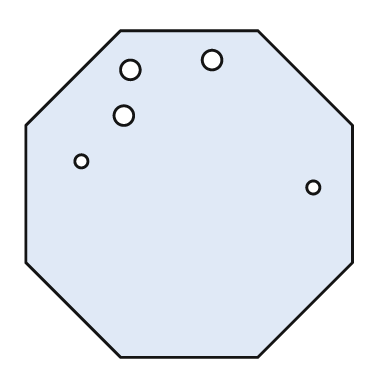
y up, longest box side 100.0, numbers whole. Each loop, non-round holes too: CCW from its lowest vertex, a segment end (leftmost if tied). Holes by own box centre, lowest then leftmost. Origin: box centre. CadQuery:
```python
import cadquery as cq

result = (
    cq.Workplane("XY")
    .moveTo(-21.0, -50.0)
    .lineTo(21.0, -50.0)
    .lineTo(50.0, -21.0)
    .lineTo(50.0, 21.0)
    .lineTo(21.0, 50.0)
    .lineTo(-21.0, 50.0)
    .lineTo(-50.0, 21.0)
    .lineTo(-50.0, -21.0)
    .close()
    .moveTo(38.0, 2.0)
    .circle(2.0)
    .moveTo(-33.0, 10.0)
    .circle(2.0)
    .moveTo(-20.0, 24.0)
    .circle(3.0)
    .moveTo(-18.0, 38.0)
    .circle(3.0)
    .moveTo(7.0, 41.0)
    .circle(3.0)
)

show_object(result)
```